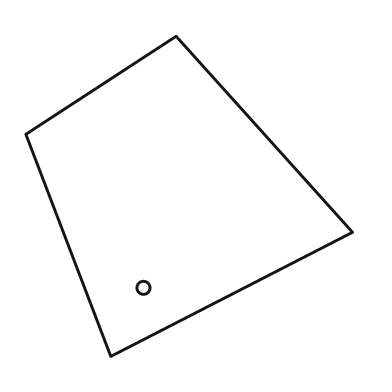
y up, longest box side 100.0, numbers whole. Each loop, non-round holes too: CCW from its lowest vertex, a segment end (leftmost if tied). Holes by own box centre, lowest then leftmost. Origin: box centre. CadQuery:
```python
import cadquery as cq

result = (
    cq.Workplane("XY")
    .moveTo(-24.0, -49.0)
    .lineTo(50.0, -11.0)
    .lineTo(-4.0, 49.0)
    .lineTo(-50.0, 19.0)
    .close()
    .moveTo(-14.0, -28.0)
    .circle(2.0)
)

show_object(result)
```